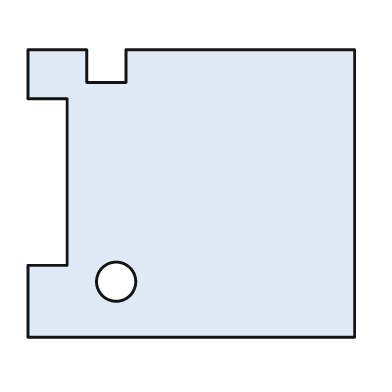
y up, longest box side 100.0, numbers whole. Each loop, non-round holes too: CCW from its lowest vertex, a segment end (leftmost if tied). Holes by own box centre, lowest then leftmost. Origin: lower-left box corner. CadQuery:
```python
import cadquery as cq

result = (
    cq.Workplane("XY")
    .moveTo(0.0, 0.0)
    .lineTo(100.0, 0.0)
    .lineTo(100.0, 88.0)
    .lineTo(30.0, 88.0)
    .lineTo(30.0, 78.0)
    .lineTo(18.0, 78.0)
    .lineTo(18.0, 88.0)
    .lineTo(0.0, 88.0)
    .lineTo(0.0, 73.0)
    .lineTo(12.0, 73.0)
    .lineTo(12.0, 22.0)
    .lineTo(0.0, 22.0)
    .close()
    .moveTo(27.0, 17.0)
    .circle(6.0)
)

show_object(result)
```